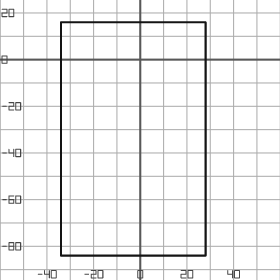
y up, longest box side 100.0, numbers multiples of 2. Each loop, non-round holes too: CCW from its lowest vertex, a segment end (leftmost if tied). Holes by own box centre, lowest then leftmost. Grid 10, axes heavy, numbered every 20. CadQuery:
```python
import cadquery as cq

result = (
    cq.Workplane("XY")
    .moveTo(-34.0, -84.0)
    .lineTo(28.0, -84.0)
    .lineTo(28.0, 16.0)
    .lineTo(-34.0, 16.0)
    .close()
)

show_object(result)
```